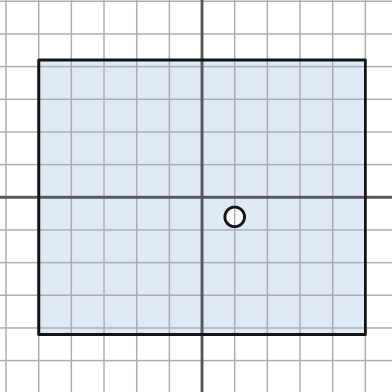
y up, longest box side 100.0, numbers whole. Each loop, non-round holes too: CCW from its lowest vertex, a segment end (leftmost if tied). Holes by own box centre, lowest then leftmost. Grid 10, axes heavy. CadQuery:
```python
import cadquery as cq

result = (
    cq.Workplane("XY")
    .moveTo(-50.0, -42.0)
    .lineTo(50.0, -42.0)
    .lineTo(50.0, 42.0)
    .lineTo(-50.0, 42.0)
    .close()
    .moveTo(10.0, -6.0)
    .circle(3.0)
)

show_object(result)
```